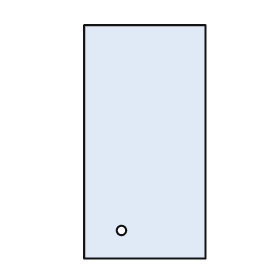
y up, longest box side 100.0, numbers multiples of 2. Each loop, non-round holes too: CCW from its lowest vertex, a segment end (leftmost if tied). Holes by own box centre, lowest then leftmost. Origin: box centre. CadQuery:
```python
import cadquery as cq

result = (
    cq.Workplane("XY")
    .moveTo(-26.0, -50.0)
    .lineTo(26.0, -50.0)
    .lineTo(26.0, 50.0)
    .lineTo(-26.0, 50.0)
    .close()
    .moveTo(-10.0, -38.0)
    .circle(2.0)
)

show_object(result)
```